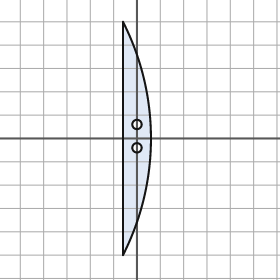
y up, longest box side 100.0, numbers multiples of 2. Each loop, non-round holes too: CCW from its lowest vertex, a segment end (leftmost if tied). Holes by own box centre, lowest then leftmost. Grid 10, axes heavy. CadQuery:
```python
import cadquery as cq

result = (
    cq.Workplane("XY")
    .moveTo(-6.0, -50.0)
    .threePointArc((6.0, 0.0), (-6.0, 50.0))
    .close()
    .moveTo(0.0, -4.0)
    .circle(2.0)
    .moveTo(0.0, 6.0)
    .circle(2.0)
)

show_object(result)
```